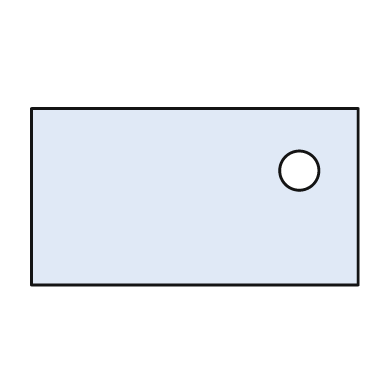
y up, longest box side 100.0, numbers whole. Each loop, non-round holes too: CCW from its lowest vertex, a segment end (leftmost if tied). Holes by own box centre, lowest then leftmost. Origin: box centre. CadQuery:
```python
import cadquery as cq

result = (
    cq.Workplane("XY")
    .moveTo(-50.0, -27.0)
    .lineTo(50.0, -27.0)
    .lineTo(50.0, 27.0)
    .lineTo(-50.0, 27.0)
    .close()
    .moveTo(32.0, 8.0)
    .circle(6.0)
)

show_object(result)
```